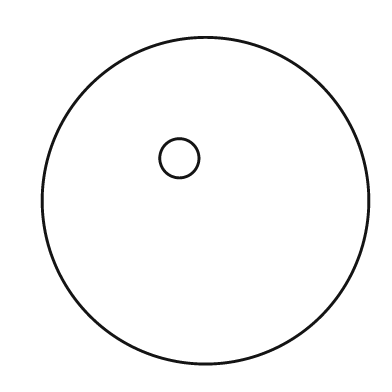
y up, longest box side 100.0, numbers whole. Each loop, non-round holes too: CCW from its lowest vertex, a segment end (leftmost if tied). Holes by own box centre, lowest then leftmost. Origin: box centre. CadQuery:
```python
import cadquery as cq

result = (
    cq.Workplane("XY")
    .moveTo(0.0, 0.0)
    .circle(50.0)
    .moveTo(-8.0, 13.0)
    .circle(6.0)
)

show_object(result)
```